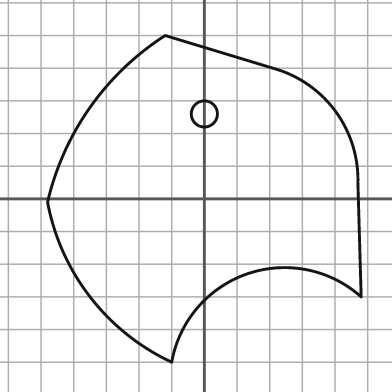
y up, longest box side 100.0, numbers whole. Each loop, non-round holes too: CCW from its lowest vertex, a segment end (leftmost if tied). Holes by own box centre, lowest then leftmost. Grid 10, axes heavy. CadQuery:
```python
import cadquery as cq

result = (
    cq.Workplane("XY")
    .moveTo(-10.0, -50.0)
    .threePointArc((13.0, -23.0), (48.0, -30.0))
    .lineTo(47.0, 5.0)
    .threePointArc((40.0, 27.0), (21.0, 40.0))
    .lineTo(-12.0, 50.0)
    .threePointArc((-35.0, 28.0), (-48.0, -1.0))
    .threePointArc((-35.0, -30.0), (-10.0, -50.0))
    .close()
    .moveTo(0.0, 26.0)
    .circle(4.0)
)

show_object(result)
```